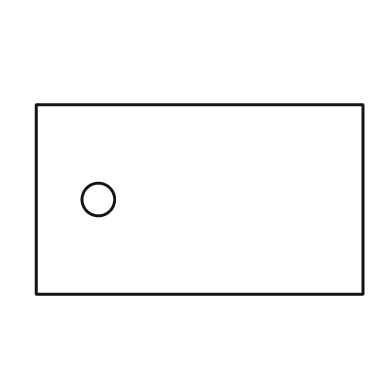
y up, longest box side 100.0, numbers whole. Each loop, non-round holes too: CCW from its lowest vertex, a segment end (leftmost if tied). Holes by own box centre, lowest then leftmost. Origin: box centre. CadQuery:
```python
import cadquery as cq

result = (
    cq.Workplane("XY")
    .moveTo(-50.0, -29.0)
    .lineTo(50.0, -29.0)
    .lineTo(50.0, 29.0)
    .lineTo(-50.0, 29.0)
    .close()
    .moveTo(-31.0, 0.0)
    .circle(5.0)
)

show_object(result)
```